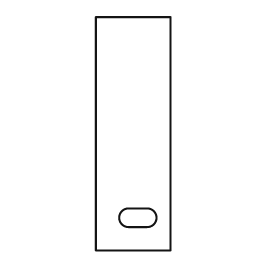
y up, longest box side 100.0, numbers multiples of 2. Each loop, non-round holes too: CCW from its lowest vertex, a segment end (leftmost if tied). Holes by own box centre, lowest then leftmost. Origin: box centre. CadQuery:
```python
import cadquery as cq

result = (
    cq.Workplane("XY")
    .moveTo(-16.0, -50.0)
    .lineTo(16.0, -50.0)
    .lineTo(16.0, 50.0)
    .lineTo(-16.0, 50.0)
    .close()
    .moveTo(-2.0, -40.0)
    .lineTo(6.0, -40.0)
    .threePointArc((10.0, -36.0), (6.0, -32.0))
    .lineTo(-2.0, -32.0)
    .threePointArc((-6.0, -36.0), (-2.0, -40.0))
    .close()
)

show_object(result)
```